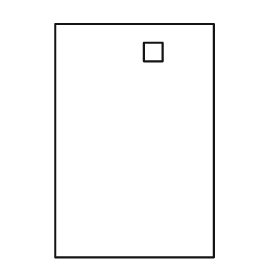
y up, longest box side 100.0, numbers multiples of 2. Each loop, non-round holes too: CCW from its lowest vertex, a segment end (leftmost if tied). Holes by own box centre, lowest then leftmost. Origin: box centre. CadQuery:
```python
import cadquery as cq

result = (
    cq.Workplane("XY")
    .moveTo(-34.0, -50.0)
    .lineTo(34.0, -50.0)
    .lineTo(34.0, 50.0)
    .lineTo(-34.0, 50.0)
    .close()
    .moveTo(4.0, 34.0)
    .lineTo(12.0, 34.0)
    .lineTo(12.0, 42.0)
    .lineTo(4.0, 42.0)
    .close()
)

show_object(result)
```